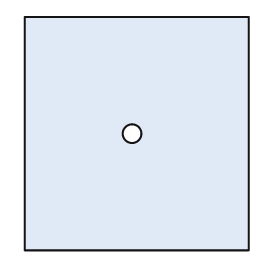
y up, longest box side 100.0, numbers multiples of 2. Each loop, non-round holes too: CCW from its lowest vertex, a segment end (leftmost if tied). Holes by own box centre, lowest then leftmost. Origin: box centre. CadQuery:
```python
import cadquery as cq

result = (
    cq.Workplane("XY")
    .moveTo(-48.0, -50.0)
    .lineTo(48.0, -50.0)
    .lineTo(48.0, 50.0)
    .lineTo(-48.0, 50.0)
    .close()
    .moveTo(-2.0, 0.0)
    .circle(4.0)
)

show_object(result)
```